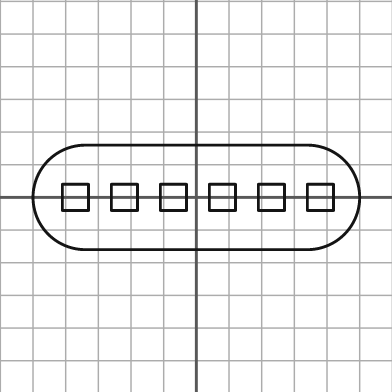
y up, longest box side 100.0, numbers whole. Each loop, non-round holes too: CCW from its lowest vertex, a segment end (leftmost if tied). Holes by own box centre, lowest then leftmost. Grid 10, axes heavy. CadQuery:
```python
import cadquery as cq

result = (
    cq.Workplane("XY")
    .moveTo(-34.0, -16.0)
    .lineTo(34.0, -16.0)
    .threePointArc((50.0, 0.0), (34.0, 16.0))
    .lineTo(-34.0, 16.0)
    .threePointArc((-50.0, 0.0), (-34.0, -16.0))
    .close()
    .moveTo(-41.0, -4.0)
    .lineTo(-33.0, -4.0)
    .lineTo(-33.0, 4.0)
    .lineTo(-41.0, 4.0)
    .close()
    .moveTo(-26.0, -4.0)
    .lineTo(-18.0, -4.0)
    .lineTo(-18.0, 4.0)
    .lineTo(-26.0, 4.0)
    .close()
    .moveTo(-11.0, -4.0)
    .lineTo(-3.0, -4.0)
    .lineTo(-3.0, 4.0)
    .lineTo(-11.0, 4.0)
    .close()
    .moveTo(4.0, -4.0)
    .lineTo(12.0, -4.0)
    .lineTo(12.0, 4.0)
    .lineTo(4.0, 4.0)
    .close()
    .moveTo(19.0, -4.0)
    .lineTo(27.0, -4.0)
    .lineTo(27.0, 4.0)
    .lineTo(19.0, 4.0)
    .close()
    .moveTo(34.0, -4.0)
    .lineTo(42.0, -4.0)
    .lineTo(42.0, 4.0)
    .lineTo(34.0, 4.0)
    .close()
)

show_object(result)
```